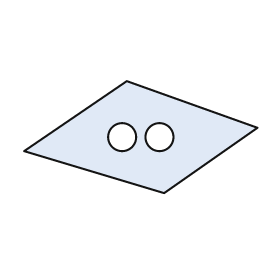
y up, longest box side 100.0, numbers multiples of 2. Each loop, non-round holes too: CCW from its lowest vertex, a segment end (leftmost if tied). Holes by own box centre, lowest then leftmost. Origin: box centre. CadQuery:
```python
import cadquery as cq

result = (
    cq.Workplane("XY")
    .moveTo(10.0, -24.0)
    .lineTo(50.0, 4.0)
    .lineTo(-6.0, 24.0)
    .lineTo(-50.0, -6.0)
    .close()
    .moveTo(-8.0, 0.0)
    .circle(6.0)
    .moveTo(8.0, 0.0)
    .circle(6.0)
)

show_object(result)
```